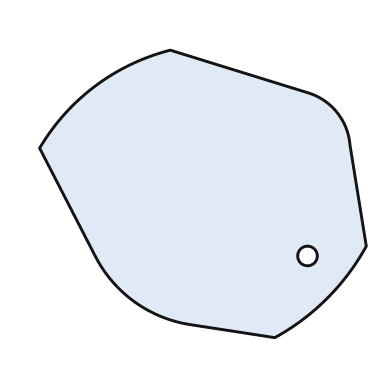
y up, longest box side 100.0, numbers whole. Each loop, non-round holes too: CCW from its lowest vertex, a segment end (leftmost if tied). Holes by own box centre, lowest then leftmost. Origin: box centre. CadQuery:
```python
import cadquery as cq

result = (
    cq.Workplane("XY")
    .moveTo(22.0, -44.0)
    .threePointArc((38.0, -32.0), (50.0, -16.0))
    .lineTo(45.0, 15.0)
    .threePointArc((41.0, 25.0), (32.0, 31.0))
    .lineTo(-10.0, 44.0)
    .threePointArc((-33.0, 33.0), (-50.0, 14.0))
    .lineTo(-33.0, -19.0)
    .threePointArc((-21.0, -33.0), (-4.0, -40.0))
    .close()
    .moveTo(32.0, -19.0)
    .circle(3.0)
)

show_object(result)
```